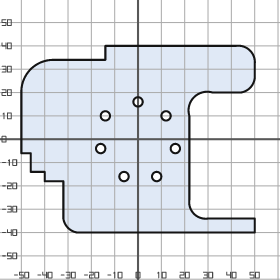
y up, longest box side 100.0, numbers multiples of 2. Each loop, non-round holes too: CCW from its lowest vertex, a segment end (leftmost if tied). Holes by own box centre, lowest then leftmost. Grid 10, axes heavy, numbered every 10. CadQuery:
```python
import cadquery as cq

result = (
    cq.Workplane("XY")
    .moveTo(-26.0, -40.0)
    .lineTo(50.0, -40.0)
    .lineTo(50.0, -34.0)
    .lineTo(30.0, -34.0)
    .threePointArc((24.0, -32.0), (22.0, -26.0))
    .lineTo(22.0, 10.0)
    .threePointArc((24.0, 18.0), (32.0, 20.0))
    .lineTo(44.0, 20.0)
    .threePointArc((48.0, 22.0), (50.0, 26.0))
    .lineTo(50.0, 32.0)
    .threePointArc((48.0, 38.0), (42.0, 40.0))
    .lineTo(-14.0, 40.0)
    .lineTo(-14.0, 34.0)
    .lineTo(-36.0, 34.0)
    .threePointArc((-46.0, 30.0), (-50.0, 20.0))
    .lineTo(-50.0, -6.0)
    .lineTo(-46.0, -6.0)
    .lineTo(-46.0, -14.0)
    .lineTo(-40.0, -14.0)
    .lineTo(-40.0, -18.0)
    .lineTo(-32.0, -18.0)
    .lineTo(-32.0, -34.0)
    .threePointArc((-30.0, -38.0), (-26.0, -40.0))
    .close()
    .moveTo(-6.0, -16.0)
    .circle(2.0)
    .moveTo(8.0, -16.0)
    .circle(2.0)
    .moveTo(-16.0, -4.0)
    .circle(2.0)
    .moveTo(16.0, -4.0)
    .circle(2.0)
    .moveTo(-14.0, 10.0)
    .circle(2.0)
    .moveTo(12.0, 10.0)
    .circle(2.0)
    .moveTo(0.0, 16.0)
    .circle(2.0)
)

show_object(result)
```